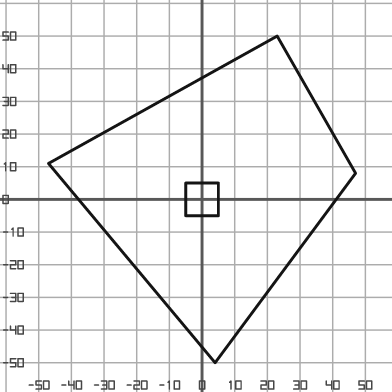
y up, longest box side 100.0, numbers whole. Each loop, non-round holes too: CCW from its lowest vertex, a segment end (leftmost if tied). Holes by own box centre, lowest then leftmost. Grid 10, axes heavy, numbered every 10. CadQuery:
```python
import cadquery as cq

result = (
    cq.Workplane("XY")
    .moveTo(4.0, -50.0)
    .lineTo(47.0, 8.0)
    .lineTo(23.0, 50.0)
    .lineTo(-47.0, 11.0)
    .close()
    .moveTo(-5.0, -5.0)
    .lineTo(5.0, -5.0)
    .lineTo(5.0, 5.0)
    .lineTo(-5.0, 5.0)
    .close()
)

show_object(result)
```